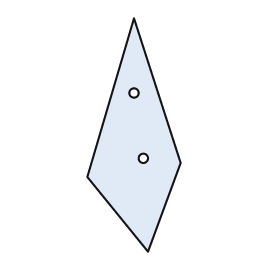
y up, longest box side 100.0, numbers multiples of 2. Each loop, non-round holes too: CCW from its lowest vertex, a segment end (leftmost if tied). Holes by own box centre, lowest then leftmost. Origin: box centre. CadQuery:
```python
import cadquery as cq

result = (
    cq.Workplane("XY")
    .moveTo(6.0, -50.0)
    .lineTo(20.0, -12.0)
    .lineTo(0.0, 50.0)
    .lineTo(-20.0, -18.0)
    .close()
    .moveTo(4.0, -10.0)
    .circle(2.0)
    .moveTo(0.0, 18.0)
    .circle(2.0)
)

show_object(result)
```